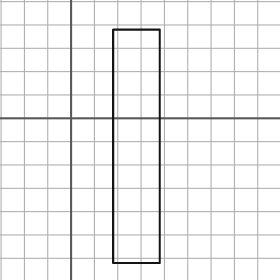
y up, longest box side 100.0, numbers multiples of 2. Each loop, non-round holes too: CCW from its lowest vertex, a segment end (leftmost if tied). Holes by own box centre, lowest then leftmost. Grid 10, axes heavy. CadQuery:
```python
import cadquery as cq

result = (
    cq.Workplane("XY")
    .moveTo(18.0, -62.0)
    .lineTo(38.0, -62.0)
    .lineTo(38.0, 38.0)
    .lineTo(18.0, 38.0)
    .close()
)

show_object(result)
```